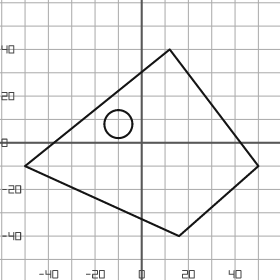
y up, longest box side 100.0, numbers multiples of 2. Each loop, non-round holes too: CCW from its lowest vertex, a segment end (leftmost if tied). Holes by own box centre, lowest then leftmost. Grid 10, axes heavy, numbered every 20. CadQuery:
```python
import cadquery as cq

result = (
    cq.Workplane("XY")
    .moveTo(16.0, -40.0)
    .lineTo(50.0, -10.0)
    .lineTo(12.0, 40.0)
    .lineTo(-50.0, -10.0)
    .close()
    .moveTo(-10.0, 8.0)
    .circle(6.0)
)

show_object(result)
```